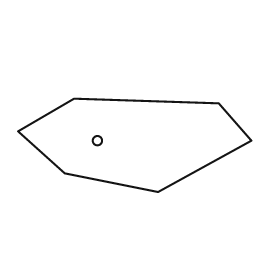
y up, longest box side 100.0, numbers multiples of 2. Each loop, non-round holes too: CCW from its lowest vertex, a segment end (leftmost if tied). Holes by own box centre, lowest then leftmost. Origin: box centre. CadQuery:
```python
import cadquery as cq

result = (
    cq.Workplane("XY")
    .moveTo(10.0, -20.0)
    .lineTo(50.0, 2.0)
    .lineTo(36.0, 18.0)
    .lineTo(-26.0, 20.0)
    .lineTo(-50.0, 6.0)
    .lineTo(-30.0, -12.0)
    .close()
    .moveTo(-16.0, 2.0)
    .circle(2.0)
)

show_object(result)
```